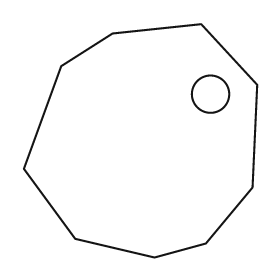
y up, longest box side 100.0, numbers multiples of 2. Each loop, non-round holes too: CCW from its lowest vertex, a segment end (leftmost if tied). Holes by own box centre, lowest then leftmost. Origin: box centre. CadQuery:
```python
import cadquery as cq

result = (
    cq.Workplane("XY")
    .moveTo(6.0, -50.0)
    .lineTo(28.0, -44.0)
    .lineTo(48.0, -20.0)
    .lineTo(50.0, 24.0)
    .lineTo(26.0, 50.0)
    .lineTo(-12.0, 46.0)
    .lineTo(-34.0, 32.0)
    .lineTo(-50.0, -12.0)
    .lineTo(-28.0, -42.0)
    .close()
    .moveTo(30.0, 20.0)
    .circle(8.0)
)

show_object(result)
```